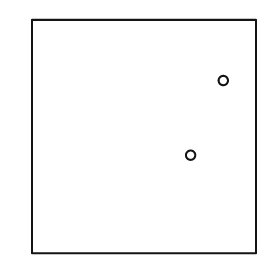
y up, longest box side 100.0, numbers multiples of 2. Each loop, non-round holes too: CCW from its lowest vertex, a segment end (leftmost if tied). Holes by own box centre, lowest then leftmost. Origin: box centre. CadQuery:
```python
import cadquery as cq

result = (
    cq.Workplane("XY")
    .moveTo(-48.0, -50.0)
    .lineTo(48.0, -50.0)
    .lineTo(48.0, 50.0)
    .lineTo(-48.0, 50.0)
    .close()
    .moveTo(20.0, -8.0)
    .circle(2.0)
    .moveTo(34.0, 24.0)
    .circle(2.0)
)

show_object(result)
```